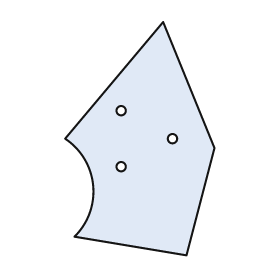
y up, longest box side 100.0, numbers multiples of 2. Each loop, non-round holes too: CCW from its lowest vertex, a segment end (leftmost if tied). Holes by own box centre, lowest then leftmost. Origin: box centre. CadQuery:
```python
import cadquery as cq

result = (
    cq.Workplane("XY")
    .moveTo(20.0, -50.0)
    .lineTo(32.0, -4.0)
    .lineTo(10.0, 50.0)
    .lineTo(-32.0, 0.0)
    .threePointArc((-20.0, -20.0), (-28.0, -42.0))
    .close()
    .moveTo(-8.0, -12.0)
    .circle(2.0)
    .moveTo(14.0, 0.0)
    .circle(2.0)
    .moveTo(-8.0, 12.0)
    .circle(2.0)
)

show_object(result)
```